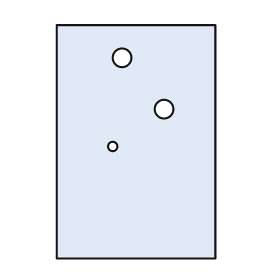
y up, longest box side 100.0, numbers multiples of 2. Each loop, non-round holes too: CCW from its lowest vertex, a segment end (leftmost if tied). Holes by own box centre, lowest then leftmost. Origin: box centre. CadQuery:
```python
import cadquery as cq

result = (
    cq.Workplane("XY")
    .moveTo(-34.0, -50.0)
    .lineTo(34.0, -50.0)
    .lineTo(34.0, 50.0)
    .lineTo(-34.0, 50.0)
    .close()
    .moveTo(-10.0, -2.0)
    .circle(2.0)
    .moveTo(12.0, 14.0)
    .circle(4.0)
    .moveTo(-6.0, 36.0)
    .circle(4.0)
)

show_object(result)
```